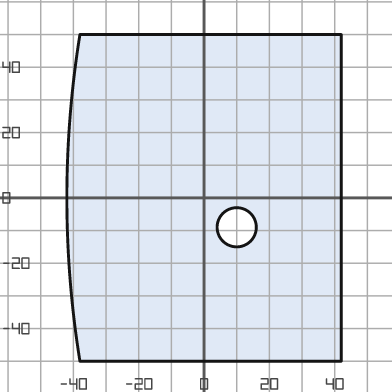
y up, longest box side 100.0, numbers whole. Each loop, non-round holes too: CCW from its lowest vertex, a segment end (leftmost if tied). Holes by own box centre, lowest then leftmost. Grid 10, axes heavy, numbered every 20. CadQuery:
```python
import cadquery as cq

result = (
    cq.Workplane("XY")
    .moveTo(-38.0, -50.0)
    .lineTo(42.0, -50.0)
    .lineTo(42.0, 50.0)
    .lineTo(-38.0, 50.0)
    .threePointArc((-42.0, 0.0), (-38.0, -50.0))
    .close()
    .moveTo(10.0, -9.0)
    .circle(6.0)
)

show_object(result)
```